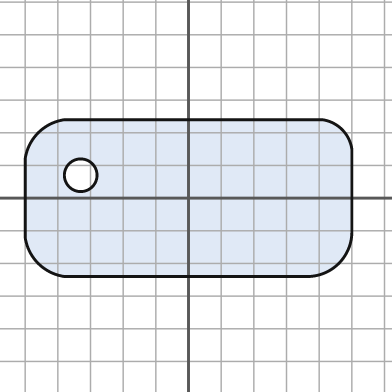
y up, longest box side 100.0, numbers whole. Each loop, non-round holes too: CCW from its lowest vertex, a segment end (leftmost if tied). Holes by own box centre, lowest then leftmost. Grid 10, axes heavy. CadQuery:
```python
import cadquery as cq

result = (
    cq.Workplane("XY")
    .moveTo(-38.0, -24.0)
    .lineTo(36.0, -24.0)
    .threePointArc((46.0, -20.0), (50.0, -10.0))
    .lineTo(50.0, 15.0)
    .threePointArc((47.0, 21.0), (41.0, 24.0))
    .lineTo(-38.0, 24.0)
    .threePointArc((-46.0, 20.0), (-50.0, 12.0))
    .lineTo(-50.0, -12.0)
    .threePointArc((-46.0, -20.0), (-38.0, -24.0))
    .close()
    .moveTo(-33.0, 7.0)
    .circle(5.0)
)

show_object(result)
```